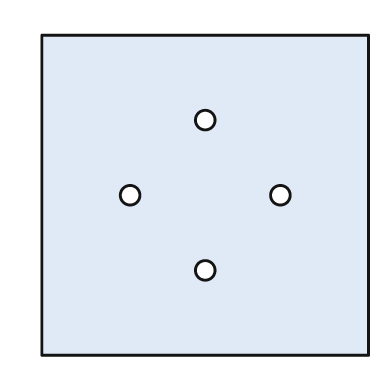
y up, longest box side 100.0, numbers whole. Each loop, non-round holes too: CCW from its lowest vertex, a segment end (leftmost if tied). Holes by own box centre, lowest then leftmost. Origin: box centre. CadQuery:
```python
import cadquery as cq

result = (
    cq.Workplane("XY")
    .moveTo(-50.0, -49.0)
    .lineTo(50.0, -49.0)
    .lineTo(50.0, 49.0)
    .lineTo(-50.0, 49.0)
    .close()
    .moveTo(0.0, -23.0)
    .circle(3.0)
    .moveTo(-23.0, 0.0)
    .circle(3.0)
    .moveTo(23.0, 0.0)
    .circle(3.0)
    .moveTo(0.0, 23.0)
    .circle(3.0)
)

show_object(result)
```